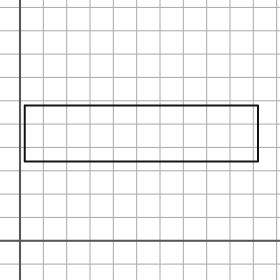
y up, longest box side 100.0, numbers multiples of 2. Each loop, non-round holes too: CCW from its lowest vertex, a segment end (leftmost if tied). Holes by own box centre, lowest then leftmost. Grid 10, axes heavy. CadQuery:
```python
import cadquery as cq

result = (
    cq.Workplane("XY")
    .moveTo(2.0, 34.0)
    .lineTo(102.0, 34.0)
    .lineTo(102.0, 58.0)
    .lineTo(2.0, 58.0)
    .close()
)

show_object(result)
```